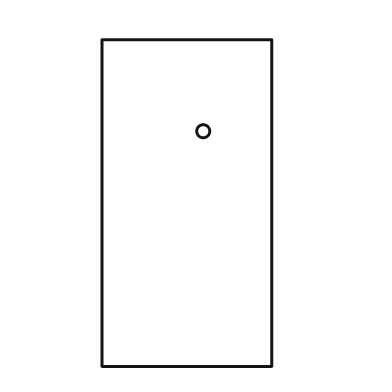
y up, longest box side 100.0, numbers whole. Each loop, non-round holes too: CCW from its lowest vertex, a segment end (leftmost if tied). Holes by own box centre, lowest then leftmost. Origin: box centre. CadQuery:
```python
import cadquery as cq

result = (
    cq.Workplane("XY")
    .moveTo(-26.0, -50.0)
    .lineTo(26.0, -50.0)
    .lineTo(26.0, 50.0)
    .lineTo(-26.0, 50.0)
    .close()
    .moveTo(5.0, 22.0)
    .circle(2.0)
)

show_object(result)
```